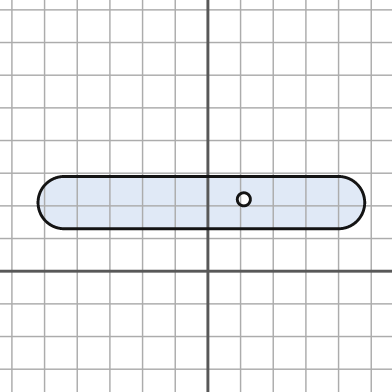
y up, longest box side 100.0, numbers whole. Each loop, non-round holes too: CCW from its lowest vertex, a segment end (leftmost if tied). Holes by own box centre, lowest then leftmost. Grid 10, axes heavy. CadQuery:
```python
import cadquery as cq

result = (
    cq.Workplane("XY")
    .moveTo(-44.0, 13.0)
    .lineTo(40.0, 13.0)
    .threePointArc((48.0, 21.0), (40.0, 29.0))
    .lineTo(-44.0, 29.0)
    .threePointArc((-52.0, 21.0), (-44.0, 13.0))
    .close()
    .moveTo(11.0, 22.0)
    .circle(2.0)
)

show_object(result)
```